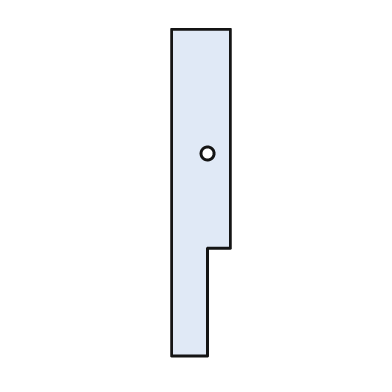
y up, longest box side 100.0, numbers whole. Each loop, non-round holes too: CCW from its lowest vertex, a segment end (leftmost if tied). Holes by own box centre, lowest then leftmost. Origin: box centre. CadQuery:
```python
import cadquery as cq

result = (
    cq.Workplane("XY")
    .moveTo(-9.0, -50.0)
    .lineTo(2.0, -50.0)
    .lineTo(2.0, -17.0)
    .lineTo(9.0, -17.0)
    .lineTo(9.0, 50.0)
    .lineTo(-9.0, 50.0)
    .close()
    .moveTo(2.0, 12.0)
    .circle(2.0)
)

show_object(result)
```